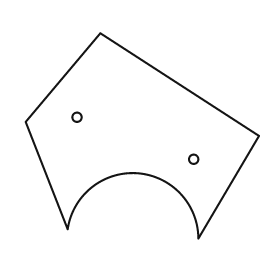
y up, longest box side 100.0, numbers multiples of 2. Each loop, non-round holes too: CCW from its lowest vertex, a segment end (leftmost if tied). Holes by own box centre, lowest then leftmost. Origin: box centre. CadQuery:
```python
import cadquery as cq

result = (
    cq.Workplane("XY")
    .moveTo(24.0, -44.0)
    .lineTo(50.0, 0.0)
    .lineTo(-18.0, 44.0)
    .lineTo(-50.0, 6.0)
    .lineTo(-32.0, -40.0)
    .threePointArc((-2.0, -16.0), (24.0, -44.0))
    .close()
    .moveTo(22.0, -10.0)
    .circle(2.0)
    .moveTo(-28.0, 8.0)
    .circle(2.0)
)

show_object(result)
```